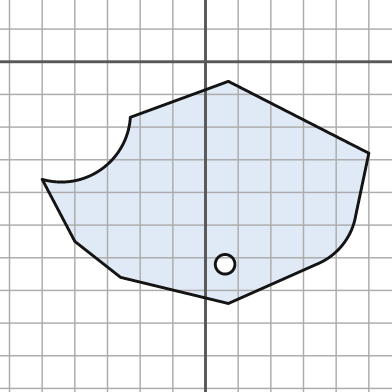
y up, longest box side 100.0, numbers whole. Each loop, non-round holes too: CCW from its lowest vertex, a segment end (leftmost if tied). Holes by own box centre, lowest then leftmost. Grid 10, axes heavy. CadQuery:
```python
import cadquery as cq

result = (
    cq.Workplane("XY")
    .moveTo(7.0, -74.0)
    .lineTo(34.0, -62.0)
    .threePointArc((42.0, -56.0), (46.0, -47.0))
    .lineTo(50.0, -28.0)
    .lineTo(7.0, -6.0)
    .lineTo(-23.0, -17.0)
    .threePointArc((-32.0, -33.0), (-50.0, -36.0))
    .lineTo(-40.0, -55.0)
    .lineTo(-26.0, -66.0)
    .close()
    .moveTo(6.0, -62.0)
    .circle(3.0)
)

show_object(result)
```